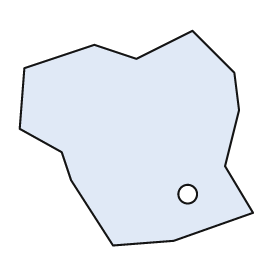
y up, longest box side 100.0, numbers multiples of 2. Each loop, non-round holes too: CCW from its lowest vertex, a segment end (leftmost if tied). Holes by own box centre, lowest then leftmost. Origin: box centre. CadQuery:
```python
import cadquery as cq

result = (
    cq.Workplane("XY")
    .moveTo(-10.0, -46.0)
    .lineTo(16.0, -44.0)
    .lineTo(50.0, -32.0)
    .lineTo(38.0, -12.0)
    .lineTo(44.0, 12.0)
    .lineTo(42.0, 28.0)
    .lineTo(24.0, 46.0)
    .lineTo(0.0, 34.0)
    .lineTo(-18.0, 40.0)
    .lineTo(-48.0, 30.0)
    .lineTo(-50.0, 4.0)
    .lineTo(-32.0, -6.0)
    .lineTo(-28.0, -18.0)
    .close()
    .moveTo(22.0, -24.0)
    .circle(4.0)
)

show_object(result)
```